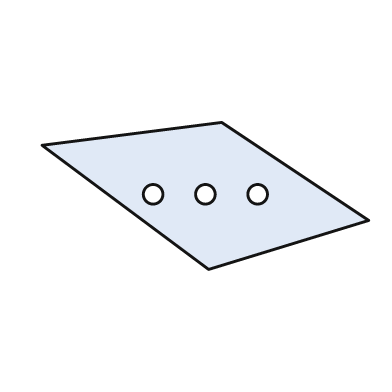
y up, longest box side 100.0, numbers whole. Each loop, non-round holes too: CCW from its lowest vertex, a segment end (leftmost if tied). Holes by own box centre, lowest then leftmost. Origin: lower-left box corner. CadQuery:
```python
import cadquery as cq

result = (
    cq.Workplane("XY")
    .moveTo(51.0, 0.0)
    .lineTo(100.0, 15.0)
    .lineTo(55.0, 45.0)
    .lineTo(0.0, 38.0)
    .close()
    .moveTo(34.0, 23.0)
    .circle(3.0)
    .moveTo(50.0, 23.0)
    .circle(3.0)
    .moveTo(66.0, 23.0)
    .circle(3.0)
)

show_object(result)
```